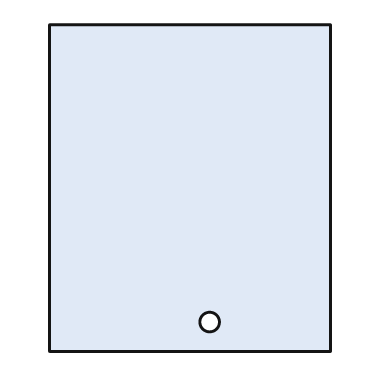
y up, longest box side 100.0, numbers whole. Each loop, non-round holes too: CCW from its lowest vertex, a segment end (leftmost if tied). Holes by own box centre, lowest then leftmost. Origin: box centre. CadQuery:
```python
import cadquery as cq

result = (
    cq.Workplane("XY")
    .moveTo(-43.0, -50.0)
    .lineTo(43.0, -50.0)
    .lineTo(43.0, 50.0)
    .lineTo(-43.0, 50.0)
    .close()
    .moveTo(6.0, -41.0)
    .circle(3.0)
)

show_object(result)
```